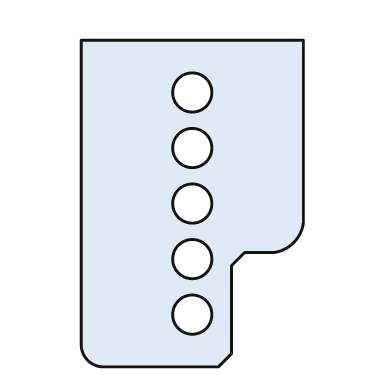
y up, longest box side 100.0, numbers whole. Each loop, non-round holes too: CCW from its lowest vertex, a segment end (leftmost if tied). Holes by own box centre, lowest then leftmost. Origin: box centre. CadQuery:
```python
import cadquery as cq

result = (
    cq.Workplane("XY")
    .moveTo(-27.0, -50.0)
    .lineTo(8.0, -50.0)
    .lineTo(12.0, -46.0)
    .lineTo(12.0, -19.0)
    .lineTo(16.0, -15.0)
    .lineTo(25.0, -15.0)
    .threePointArc((31.0, -12.0), (34.0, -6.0))
    .lineTo(34.0, 50.0)
    .lineTo(-34.0, 50.0)
    .lineTo(-34.0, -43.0)
    .threePointArc((-32.0, -48.0), (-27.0, -50.0))
    .close()
    .moveTo(0.0, -34.0)
    .circle(6.0)
    .moveTo(0.0, -17.0)
    .circle(6.0)
    .moveTo(0.0, 0.0)
    .circle(6.0)
    .moveTo(0.0, 17.0)
    .circle(6.0)
    .moveTo(0.0, 34.0)
    .circle(6.0)
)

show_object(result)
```